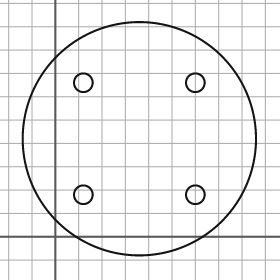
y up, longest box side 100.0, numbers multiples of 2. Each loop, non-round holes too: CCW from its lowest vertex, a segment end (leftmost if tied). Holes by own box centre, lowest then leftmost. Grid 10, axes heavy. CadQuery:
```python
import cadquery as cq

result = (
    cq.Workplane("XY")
    .moveTo(36.0, 42.0)
    .circle(50.0)
    .moveTo(12.0, 18.0)
    .circle(4.0)
    .moveTo(60.0, 18.0)
    .circle(4.0)
    .moveTo(12.0, 66.0)
    .circle(4.0)
    .moveTo(60.0, 66.0)
    .circle(4.0)
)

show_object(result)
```